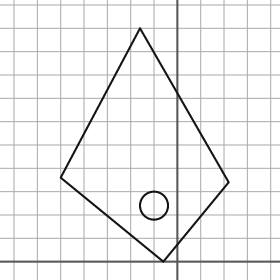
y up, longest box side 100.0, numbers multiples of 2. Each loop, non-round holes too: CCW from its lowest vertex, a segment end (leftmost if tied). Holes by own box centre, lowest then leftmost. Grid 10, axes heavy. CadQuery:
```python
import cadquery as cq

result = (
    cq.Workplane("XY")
    .moveTo(-6.0, 0.0)
    .lineTo(22.0, 34.0)
    .lineTo(-16.0, 100.0)
    .lineTo(-50.0, 36.0)
    .close()
    .moveTo(-10.0, 24.0)
    .circle(6.0)
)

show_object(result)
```